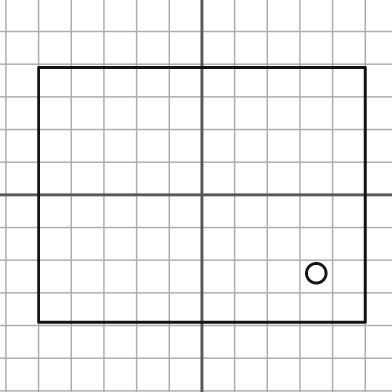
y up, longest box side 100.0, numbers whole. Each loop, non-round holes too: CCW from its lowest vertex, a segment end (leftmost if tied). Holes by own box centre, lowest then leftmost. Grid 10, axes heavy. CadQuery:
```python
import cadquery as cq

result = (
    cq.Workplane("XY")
    .moveTo(-50.0, -39.0)
    .lineTo(50.0, -39.0)
    .lineTo(50.0, 39.0)
    .lineTo(-50.0, 39.0)
    .close()
    .moveTo(35.0, -24.0)
    .circle(3.0)
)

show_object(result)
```